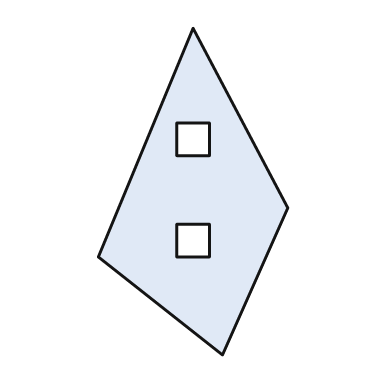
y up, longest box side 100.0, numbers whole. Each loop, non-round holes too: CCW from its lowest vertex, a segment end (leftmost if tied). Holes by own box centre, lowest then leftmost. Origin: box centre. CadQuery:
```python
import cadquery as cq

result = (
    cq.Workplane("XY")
    .moveTo(9.0, -50.0)
    .lineTo(29.0, -5.0)
    .lineTo(0.0, 50.0)
    .lineTo(-29.0, -20.0)
    .close()
    .moveTo(-5.0, -20.0)
    .lineTo(5.0, -20.0)
    .lineTo(5.0, -10.0)
    .lineTo(-5.0, -10.0)
    .close()
    .moveTo(-5.0, 11.0)
    .lineTo(5.0, 11.0)
    .lineTo(5.0, 21.0)
    .lineTo(-5.0, 21.0)
    .close()
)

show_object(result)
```